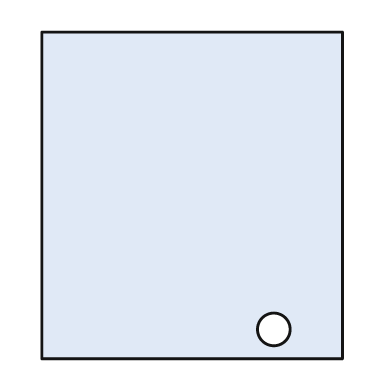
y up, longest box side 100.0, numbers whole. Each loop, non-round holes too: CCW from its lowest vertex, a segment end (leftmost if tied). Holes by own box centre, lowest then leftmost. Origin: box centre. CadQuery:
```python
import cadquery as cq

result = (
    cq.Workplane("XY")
    .moveTo(-46.0, -50.0)
    .lineTo(46.0, -50.0)
    .lineTo(46.0, 50.0)
    .lineTo(-46.0, 50.0)
    .close()
    .moveTo(25.0, -41.0)
    .circle(5.0)
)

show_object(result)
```